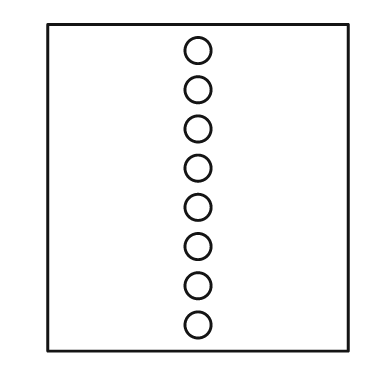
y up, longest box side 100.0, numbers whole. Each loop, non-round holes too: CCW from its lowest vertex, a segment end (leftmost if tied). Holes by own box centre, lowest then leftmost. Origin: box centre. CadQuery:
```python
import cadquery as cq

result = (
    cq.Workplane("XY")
    .moveTo(-46.0, -50.0)
    .lineTo(46.0, -50.0)
    .lineTo(46.0, 50.0)
    .lineTo(-46.0, 50.0)
    .close()
    .moveTo(0.0, -42.0)
    .circle(4.0)
    .moveTo(0.0, -30.0)
    .circle(4.0)
    .moveTo(0.0, -18.0)
    .circle(4.0)
    .moveTo(0.0, -6.0)
    .circle(4.0)
    .moveTo(0.0, 6.0)
    .circle(4.0)
    .moveTo(0.0, 18.0)
    .circle(4.0)
    .moveTo(0.0, 30.0)
    .circle(4.0)
    .moveTo(0.0, 42.0)
    .circle(4.0)
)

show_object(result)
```